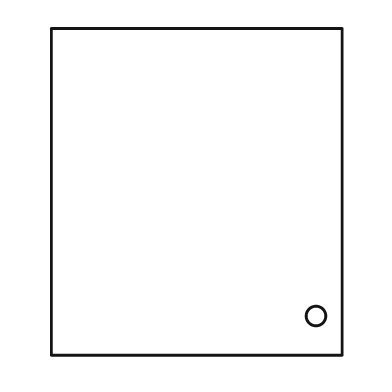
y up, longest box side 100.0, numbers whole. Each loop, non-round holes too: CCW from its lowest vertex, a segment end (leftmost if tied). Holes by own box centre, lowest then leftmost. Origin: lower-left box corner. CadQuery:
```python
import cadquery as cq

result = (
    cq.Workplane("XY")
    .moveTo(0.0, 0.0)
    .lineTo(89.0, 0.0)
    .lineTo(89.0, 100.0)
    .lineTo(0.0, 100.0)
    .close()
    .moveTo(81.0, 12.0)
    .circle(3.0)
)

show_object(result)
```